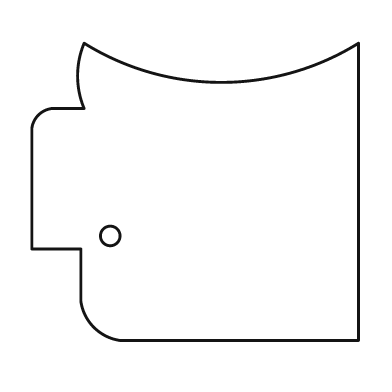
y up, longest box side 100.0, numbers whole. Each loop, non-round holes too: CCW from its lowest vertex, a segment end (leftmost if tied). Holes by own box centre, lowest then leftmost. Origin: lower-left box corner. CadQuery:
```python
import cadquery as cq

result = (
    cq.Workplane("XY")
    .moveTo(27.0, 0.0)
    .lineTo(100.0, 0.0)
    .lineTo(100.0, 91.0)
    .threePointArc((58.0, 79.0), (16.0, 91.0))
    .threePointArc((14.0, 81.0), (16.0, 71.0))
    .lineTo(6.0, 71.0)
    .threePointArc((2.0, 69.0), (0.0, 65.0))
    .lineTo(0.0, 28.0)
    .lineTo(15.0, 28.0)
    .lineTo(15.0, 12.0)
    .threePointArc((19.0, 4.0), (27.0, 0.0))
    .close()
    .moveTo(24.0, 32.0)
    .circle(3.0)
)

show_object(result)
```